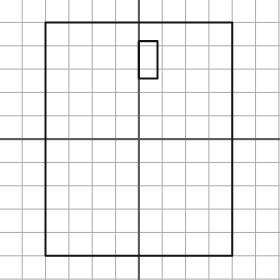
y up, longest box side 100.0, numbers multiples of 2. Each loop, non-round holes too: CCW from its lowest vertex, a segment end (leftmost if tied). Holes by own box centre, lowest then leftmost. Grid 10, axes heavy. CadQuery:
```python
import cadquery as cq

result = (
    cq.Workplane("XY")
    .moveTo(-40.0, -50.0)
    .lineTo(40.0, -50.0)
    .lineTo(40.0, 50.0)
    .lineTo(-40.0, 50.0)
    .close()
    .moveTo(0.0, 26.0)
    .lineTo(8.0, 26.0)
    .lineTo(8.0, 42.0)
    .lineTo(0.0, 42.0)
    .close()
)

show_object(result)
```